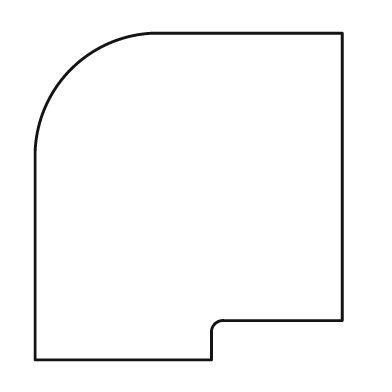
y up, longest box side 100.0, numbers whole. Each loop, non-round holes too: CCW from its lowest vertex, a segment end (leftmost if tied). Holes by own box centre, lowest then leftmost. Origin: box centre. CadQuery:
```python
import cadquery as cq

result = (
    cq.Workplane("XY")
    .moveTo(-47.0, -50.0)
    .lineTo(7.0, -50.0)
    .lineTo(7.0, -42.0)
    .threePointArc((8.0, -39.0), (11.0, -38.0))
    .lineTo(47.0, -38.0)
    .lineTo(47.0, 50.0)
    .lineTo(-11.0, 50.0)
    .threePointArc((-36.0, 39.0), (-47.0, 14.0))
    .close()
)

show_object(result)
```